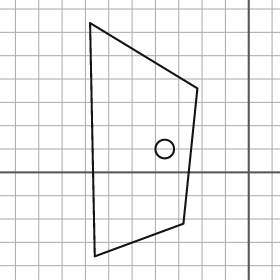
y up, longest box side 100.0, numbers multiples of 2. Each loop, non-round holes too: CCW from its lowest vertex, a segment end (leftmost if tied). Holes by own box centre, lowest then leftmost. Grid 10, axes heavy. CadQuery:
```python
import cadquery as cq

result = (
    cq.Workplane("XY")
    .moveTo(-66.0, -36.0)
    .lineTo(-28.0, -22.0)
    .lineTo(-22.0, 36.0)
    .lineTo(-68.0, 64.0)
    .close()
    .moveTo(-36.0, 10.0)
    .circle(4.0)
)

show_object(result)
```